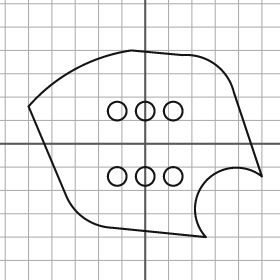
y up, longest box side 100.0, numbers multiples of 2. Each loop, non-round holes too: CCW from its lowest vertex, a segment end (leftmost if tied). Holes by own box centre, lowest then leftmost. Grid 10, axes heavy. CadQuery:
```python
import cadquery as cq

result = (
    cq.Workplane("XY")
    .moveTo(26.0, -40.0)
    .threePointArc((26.0, -16.0), (50.0, -14.0))
    .lineTo(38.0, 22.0)
    .threePointArc((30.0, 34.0), (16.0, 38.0))
    .lineTo(-6.0, 40.0)
    .threePointArc((-30.0, 32.0), (-50.0, 16.0))
    .lineTo(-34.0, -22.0)
    .threePointArc((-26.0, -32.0), (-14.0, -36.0))
    .close()
    .moveTo(-12.0, -14.0)
    .circle(4.0)
    .moveTo(0.0, -14.0)
    .circle(4.0)
    .moveTo(12.0, -14.0)
    .circle(4.0)
    .moveTo(-12.0, 14.0)
    .circle(4.0)
    .moveTo(0.0, 14.0)
    .circle(4.0)
    .moveTo(12.0, 14.0)
    .circle(4.0)
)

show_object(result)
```